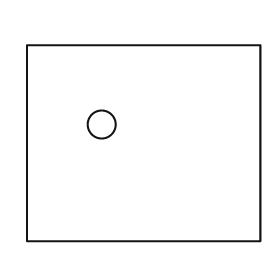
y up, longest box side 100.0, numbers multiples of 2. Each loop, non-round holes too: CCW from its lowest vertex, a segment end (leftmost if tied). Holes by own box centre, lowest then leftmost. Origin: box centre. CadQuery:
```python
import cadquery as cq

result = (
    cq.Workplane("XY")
    .moveTo(-50.0, -42.0)
    .lineTo(50.0, -42.0)
    .lineTo(50.0, 42.0)
    .lineTo(-50.0, 42.0)
    .close()
    .moveTo(-18.0, 8.0)
    .circle(6.0)
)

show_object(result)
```